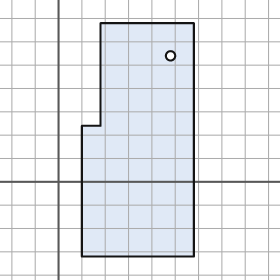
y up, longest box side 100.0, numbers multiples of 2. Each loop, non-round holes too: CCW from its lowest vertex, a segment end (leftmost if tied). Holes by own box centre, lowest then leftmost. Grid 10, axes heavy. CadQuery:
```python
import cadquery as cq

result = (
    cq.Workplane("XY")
    .moveTo(10.0, -32.0)
    .lineTo(58.0, -32.0)
    .lineTo(58.0, 68.0)
    .lineTo(18.0, 68.0)
    .lineTo(18.0, 24.0)
    .lineTo(10.0, 24.0)
    .close()
    .moveTo(48.0, 54.0)
    .circle(2.0)
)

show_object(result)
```